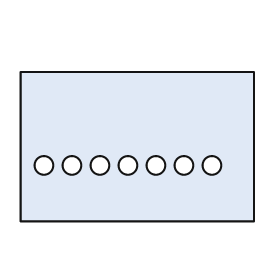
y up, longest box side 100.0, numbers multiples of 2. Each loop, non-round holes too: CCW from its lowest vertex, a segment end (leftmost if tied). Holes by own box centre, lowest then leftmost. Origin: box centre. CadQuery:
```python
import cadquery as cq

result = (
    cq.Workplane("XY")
    .moveTo(-50.0, -32.0)
    .lineTo(50.0, -32.0)
    .lineTo(50.0, 32.0)
    .lineTo(-50.0, 32.0)
    .close()
    .moveTo(-40.0, -8.0)
    .circle(4.0)
    .moveTo(-28.0, -8.0)
    .circle(4.0)
    .moveTo(-16.0, -8.0)
    .circle(4.0)
    .moveTo(-4.0, -8.0)
    .circle(4.0)
    .moveTo(8.0, -8.0)
    .circle(4.0)
    .moveTo(20.0, -8.0)
    .circle(4.0)
    .moveTo(32.0, -8.0)
    .circle(4.0)
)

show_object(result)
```